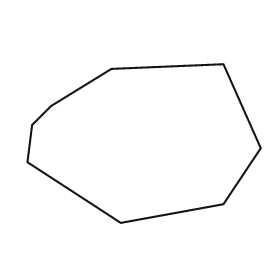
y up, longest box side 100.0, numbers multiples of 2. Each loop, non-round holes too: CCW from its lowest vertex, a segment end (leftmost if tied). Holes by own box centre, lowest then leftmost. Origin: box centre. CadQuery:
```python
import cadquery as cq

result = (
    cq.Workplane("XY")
    .moveTo(-10.0, -34.0)
    .lineTo(34.0, -26.0)
    .lineTo(50.0, -2.0)
    .lineTo(34.0, 34.0)
    .lineTo(-14.0, 32.0)
    .lineTo(-40.0, 16.0)
    .lineTo(-48.0, 8.0)
    .lineTo(-50.0, -8.0)
    .close()
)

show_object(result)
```